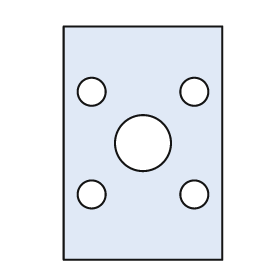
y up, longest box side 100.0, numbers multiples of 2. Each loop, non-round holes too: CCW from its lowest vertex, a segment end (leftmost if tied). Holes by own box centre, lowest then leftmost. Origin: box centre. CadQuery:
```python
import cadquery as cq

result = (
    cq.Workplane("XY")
    .moveTo(-34.0, -50.0)
    .lineTo(34.0, -50.0)
    .lineTo(34.0, 50.0)
    .lineTo(-34.0, 50.0)
    .close()
    .moveTo(-22.0, -22.0)
    .circle(6.0)
    .moveTo(22.0, -22.0)
    .circle(6.0)
    .moveTo(0.0, 0.0)
    .circle(12.0)
    .moveTo(-22.0, 22.0)
    .circle(6.0)
    .moveTo(22.0, 22.0)
    .circle(6.0)
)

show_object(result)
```